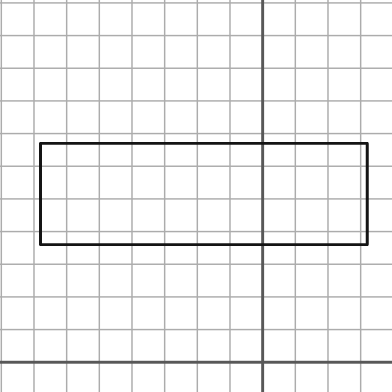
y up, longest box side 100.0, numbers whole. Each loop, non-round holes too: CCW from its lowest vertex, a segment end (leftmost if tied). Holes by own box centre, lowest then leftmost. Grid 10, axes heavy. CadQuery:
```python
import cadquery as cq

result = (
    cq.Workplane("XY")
    .moveTo(-68.0, 36.0)
    .lineTo(32.0, 36.0)
    .lineTo(32.0, 67.0)
    .lineTo(-68.0, 67.0)
    .close()
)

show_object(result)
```